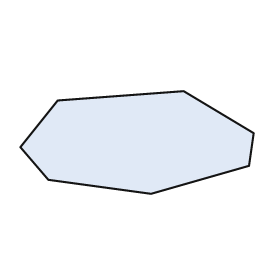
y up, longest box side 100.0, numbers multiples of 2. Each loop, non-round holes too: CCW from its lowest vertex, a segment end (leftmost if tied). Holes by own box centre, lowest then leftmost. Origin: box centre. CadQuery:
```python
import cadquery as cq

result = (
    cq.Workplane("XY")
    .moveTo(6.0, -22.0)
    .lineTo(48.0, -10.0)
    .lineTo(50.0, 4.0)
    .lineTo(20.0, 22.0)
    .lineTo(-34.0, 18.0)
    .lineTo(-50.0, -2.0)
    .lineTo(-38.0, -16.0)
    .close()
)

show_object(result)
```